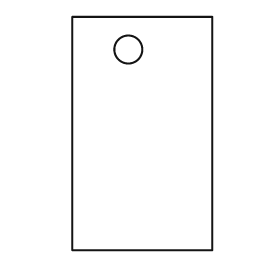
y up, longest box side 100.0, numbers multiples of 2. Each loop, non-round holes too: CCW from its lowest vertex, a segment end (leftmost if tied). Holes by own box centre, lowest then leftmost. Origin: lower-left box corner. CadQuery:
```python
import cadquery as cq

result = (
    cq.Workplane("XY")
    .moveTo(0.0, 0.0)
    .lineTo(60.0, 0.0)
    .lineTo(60.0, 100.0)
    .lineTo(0.0, 100.0)
    .close()
    .moveTo(24.0, 86.0)
    .circle(6.0)
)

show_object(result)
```